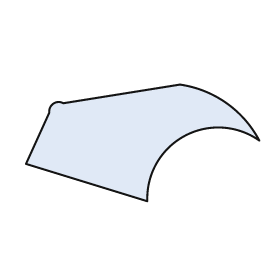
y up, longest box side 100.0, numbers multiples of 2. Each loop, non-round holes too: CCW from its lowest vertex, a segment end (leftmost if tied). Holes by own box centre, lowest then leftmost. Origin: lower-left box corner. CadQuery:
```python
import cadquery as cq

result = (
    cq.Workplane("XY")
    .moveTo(52.0, 0.0)
    .threePointArc((68.0, 28.0), (100.0, 26.0))
    .threePointArc((86.0, 42.0), (66.0, 50.0))
    .lineTo(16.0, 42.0)
    .threePointArc((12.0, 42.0), (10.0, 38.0))
    .lineTo(0.0, 16.0)
    .close()
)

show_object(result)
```